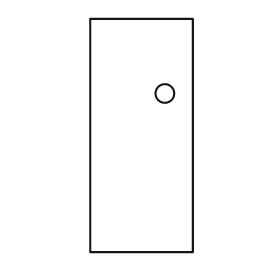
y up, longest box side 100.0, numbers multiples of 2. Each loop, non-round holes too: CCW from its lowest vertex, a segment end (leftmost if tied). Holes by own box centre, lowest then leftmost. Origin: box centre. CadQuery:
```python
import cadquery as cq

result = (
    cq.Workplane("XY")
    .moveTo(-22.0, -50.0)
    .lineTo(22.0, -50.0)
    .lineTo(22.0, 50.0)
    .lineTo(-22.0, 50.0)
    .close()
    .moveTo(10.0, 18.0)
    .circle(4.0)
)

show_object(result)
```